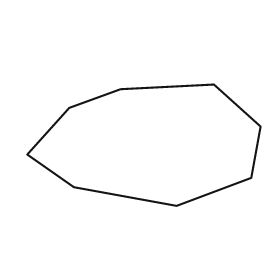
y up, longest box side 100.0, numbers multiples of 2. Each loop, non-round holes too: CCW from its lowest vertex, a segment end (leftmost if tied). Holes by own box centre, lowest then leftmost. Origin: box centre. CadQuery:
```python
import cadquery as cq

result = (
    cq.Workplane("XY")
    .moveTo(14.0, -26.0)
    .lineTo(46.0, -14.0)
    .lineTo(50.0, 8.0)
    .lineTo(30.0, 26.0)
    .lineTo(-10.0, 24.0)
    .lineTo(-32.0, 16.0)
    .lineTo(-50.0, -4.0)
    .lineTo(-30.0, -18.0)
    .close()
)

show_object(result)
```